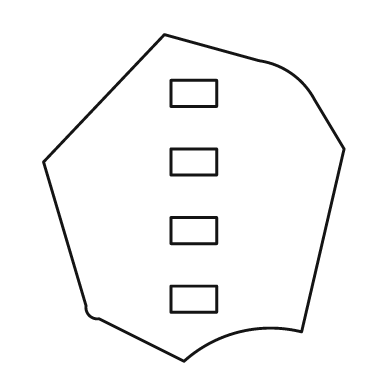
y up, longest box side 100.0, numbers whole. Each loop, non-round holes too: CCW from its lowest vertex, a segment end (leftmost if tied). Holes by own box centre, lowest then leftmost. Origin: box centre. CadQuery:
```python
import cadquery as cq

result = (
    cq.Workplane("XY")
    .moveTo(-3.0, -50.0)
    .threePointArc((14.0, -41.0), (33.0, -41.0))
    .lineTo(46.0, 15.0)
    .lineTo(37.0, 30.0)
    .threePointArc((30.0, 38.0), (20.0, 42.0))
    .lineTo(-9.0, 50.0)
    .lineTo(-46.0, 11.0)
    .lineTo(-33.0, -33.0)
    .threePointArc((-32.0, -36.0), (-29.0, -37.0))
    .close()
    .moveTo(-7.0, -35.0)
    .lineTo(7.0, -35.0)
    .lineTo(7.0, -27.0)
    .lineTo(-7.0, -27.0)
    .close()
    .moveTo(-7.0, -14.0)
    .lineTo(7.0, -14.0)
    .lineTo(7.0, -6.0)
    .lineTo(-7.0, -6.0)
    .close()
    .moveTo(-7.0, 7.0)
    .lineTo(7.0, 7.0)
    .lineTo(7.0, 15.0)
    .lineTo(-7.0, 15.0)
    .close()
    .moveTo(-7.0, 28.0)
    .lineTo(7.0, 28.0)
    .lineTo(7.0, 36.0)
    .lineTo(-7.0, 36.0)
    .close()
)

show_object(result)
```